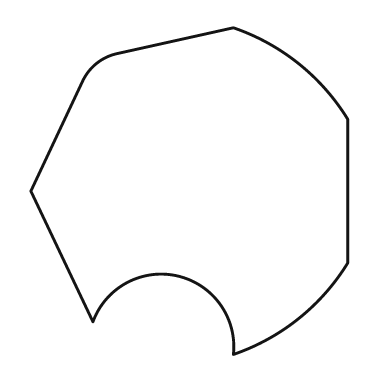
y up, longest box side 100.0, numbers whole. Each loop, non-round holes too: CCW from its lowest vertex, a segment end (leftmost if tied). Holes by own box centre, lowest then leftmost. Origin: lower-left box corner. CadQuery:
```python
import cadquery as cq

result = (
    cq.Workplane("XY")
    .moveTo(62.0, 0.0)
    .threePointArc((82.0, 11.0), (97.0, 28.0))
    .lineTo(97.0, 72.0)
    .threePointArc((82.0, 89.0), (62.0, 100.0))
    .lineTo(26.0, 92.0)
    .threePointArc((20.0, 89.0), (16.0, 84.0))
    .lineTo(0.0, 50.0)
    .lineTo(19.0, 10.0)
    .threePointArc((45.0, 24.0), (62.0, 0.0))
    .close()
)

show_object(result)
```